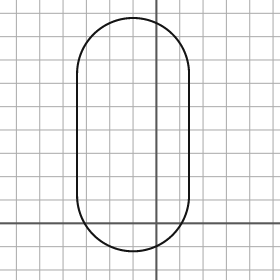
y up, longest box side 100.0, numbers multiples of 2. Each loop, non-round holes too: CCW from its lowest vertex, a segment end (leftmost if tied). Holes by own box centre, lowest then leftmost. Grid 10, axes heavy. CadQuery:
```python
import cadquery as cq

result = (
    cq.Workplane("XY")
    .moveTo(-34.0, 12.0)
    .threePointArc((-10.0, -12.0), (14.0, 12.0))
    .lineTo(14.0, 64.0)
    .threePointArc((-10.0, 88.0), (-34.0, 64.0))
    .close()
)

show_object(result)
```